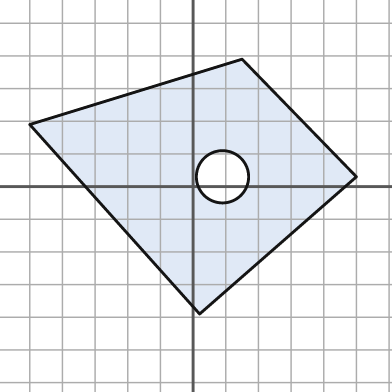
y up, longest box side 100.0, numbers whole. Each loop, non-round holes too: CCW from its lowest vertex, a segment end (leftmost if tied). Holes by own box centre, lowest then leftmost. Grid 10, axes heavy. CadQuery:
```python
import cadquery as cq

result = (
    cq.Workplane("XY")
    .moveTo(2.0, -39.0)
    .lineTo(50.0, 3.0)
    .lineTo(15.0, 39.0)
    .lineTo(-50.0, 19.0)
    .close()
    .moveTo(9.0, 3.0)
    .circle(8.0)
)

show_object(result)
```